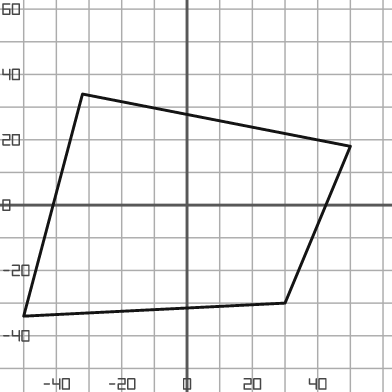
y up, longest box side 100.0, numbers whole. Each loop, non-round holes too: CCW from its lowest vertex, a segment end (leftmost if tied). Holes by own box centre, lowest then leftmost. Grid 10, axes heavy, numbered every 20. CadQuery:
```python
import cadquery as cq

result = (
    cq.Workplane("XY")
    .moveTo(-50.0, -34.0)
    .lineTo(30.0, -30.0)
    .lineTo(50.0, 18.0)
    .lineTo(-32.0, 34.0)
    .close()
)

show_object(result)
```